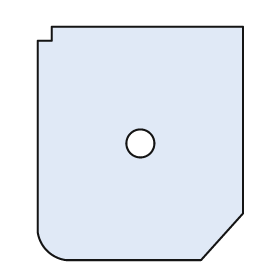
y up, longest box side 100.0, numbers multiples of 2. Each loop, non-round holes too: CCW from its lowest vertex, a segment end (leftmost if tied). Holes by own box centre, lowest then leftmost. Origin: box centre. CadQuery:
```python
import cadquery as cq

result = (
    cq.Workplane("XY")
    .moveTo(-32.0, -50.0)
    .lineTo(26.0, -50.0)
    .lineTo(44.0, -30.0)
    .lineTo(44.0, 50.0)
    .lineTo(-38.0, 50.0)
    .lineTo(-38.0, 44.0)
    .lineTo(-44.0, 44.0)
    .lineTo(-44.0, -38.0)
    .threePointArc((-40.0, -46.0), (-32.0, -50.0))
    .close()
    .moveTo(0.0, 0.0)
    .circle(6.0)
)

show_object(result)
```